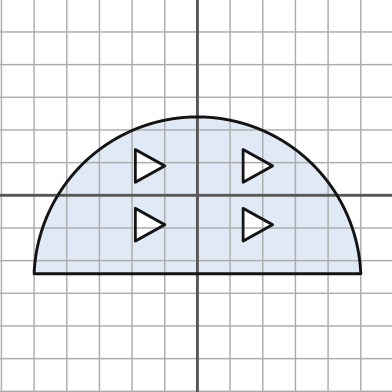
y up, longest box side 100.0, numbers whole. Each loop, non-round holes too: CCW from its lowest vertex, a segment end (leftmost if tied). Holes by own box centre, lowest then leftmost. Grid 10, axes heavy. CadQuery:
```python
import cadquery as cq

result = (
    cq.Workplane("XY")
    .moveTo(-50.0, -24.0)
    .lineTo(50.0, -24.0)
    .threePointArc((0.0, 24.0), (-50.0, -24.0))
    .close()
    .moveTo(-19.0, -14.0)
    .lineTo(-10.0, -9.0)
    .lineTo(-19.0, -4.0)
    .close()
    .moveTo(14.0, -14.0)
    .lineTo(23.0, -9.0)
    .lineTo(14.0, -4.0)
    .close()
    .moveTo(-19.0, 4.0)
    .lineTo(-10.0, 9.0)
    .lineTo(-19.0, 14.0)
    .close()
    .moveTo(14.0, 4.0)
    .lineTo(23.0, 9.0)
    .lineTo(14.0, 14.0)
    .close()
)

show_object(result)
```